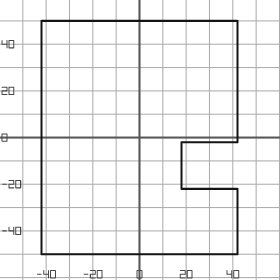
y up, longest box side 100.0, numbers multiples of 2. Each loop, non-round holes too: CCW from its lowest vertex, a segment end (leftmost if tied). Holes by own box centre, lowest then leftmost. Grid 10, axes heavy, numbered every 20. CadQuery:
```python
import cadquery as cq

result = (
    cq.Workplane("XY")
    .moveTo(-42.0, -50.0)
    .lineTo(42.0, -50.0)
    .lineTo(42.0, -22.0)
    .lineTo(18.0, -22.0)
    .lineTo(18.0, -2.0)
    .lineTo(42.0, -2.0)
    .lineTo(42.0, 50.0)
    .lineTo(-42.0, 50.0)
    .close()
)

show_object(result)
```